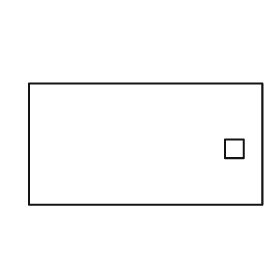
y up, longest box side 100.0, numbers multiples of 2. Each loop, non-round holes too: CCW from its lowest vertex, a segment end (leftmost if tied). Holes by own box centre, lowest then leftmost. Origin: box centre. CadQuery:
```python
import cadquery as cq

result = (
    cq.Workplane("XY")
    .moveTo(-50.0, -26.0)
    .lineTo(50.0, -26.0)
    .lineTo(50.0, 26.0)
    .lineTo(-50.0, 26.0)
    .close()
    .moveTo(34.0, -6.0)
    .lineTo(42.0, -6.0)
    .lineTo(42.0, 2.0)
    .lineTo(34.0, 2.0)
    .close()
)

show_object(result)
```